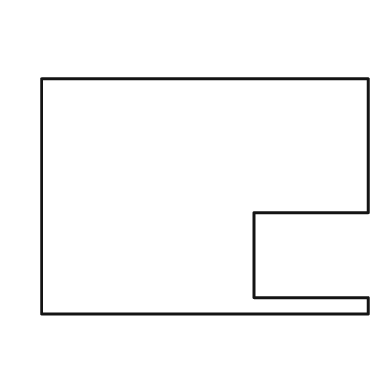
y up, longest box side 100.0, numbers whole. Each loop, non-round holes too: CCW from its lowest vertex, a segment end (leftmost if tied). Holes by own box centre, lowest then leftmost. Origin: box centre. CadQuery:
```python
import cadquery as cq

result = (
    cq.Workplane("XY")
    .moveTo(-50.0, -36.0)
    .lineTo(50.0, -36.0)
    .lineTo(50.0, -31.0)
    .lineTo(15.0, -31.0)
    .lineTo(15.0, -5.0)
    .lineTo(50.0, -5.0)
    .lineTo(50.0, 36.0)
    .lineTo(-50.0, 36.0)
    .close()
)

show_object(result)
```